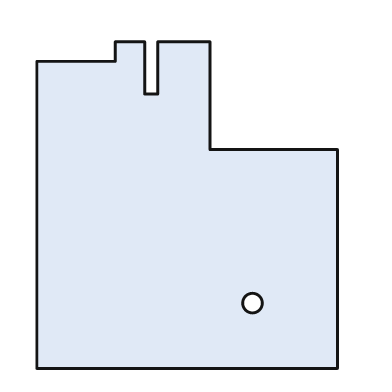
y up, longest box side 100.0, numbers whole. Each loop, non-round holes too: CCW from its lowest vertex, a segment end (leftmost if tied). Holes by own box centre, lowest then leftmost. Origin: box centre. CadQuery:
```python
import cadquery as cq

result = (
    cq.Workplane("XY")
    .moveTo(-46.0, -50.0)
    .lineTo(46.0, -50.0)
    .lineTo(46.0, 17.0)
    .lineTo(7.0, 17.0)
    .lineTo(7.0, 50.0)
    .lineTo(-9.0, 50.0)
    .lineTo(-9.0, 34.0)
    .lineTo(-13.0, 34.0)
    .lineTo(-13.0, 50.0)
    .lineTo(-22.0, 50.0)
    .lineTo(-22.0, 44.0)
    .lineTo(-46.0, 44.0)
    .close()
    .moveTo(20.0, -30.0)
    .circle(3.0)
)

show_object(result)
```